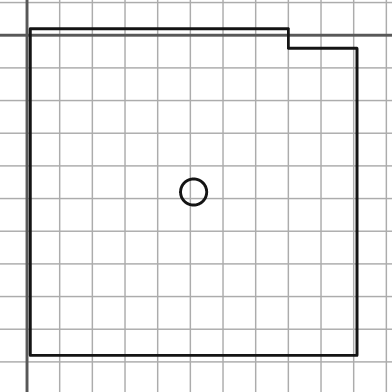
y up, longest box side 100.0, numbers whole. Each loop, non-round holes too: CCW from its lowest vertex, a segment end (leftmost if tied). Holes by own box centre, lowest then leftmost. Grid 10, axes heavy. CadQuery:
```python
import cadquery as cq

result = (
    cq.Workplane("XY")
    .moveTo(1.0, -98.0)
    .lineTo(101.0, -98.0)
    .lineTo(101.0, -4.0)
    .lineTo(80.0, -4.0)
    .lineTo(80.0, 2.0)
    .lineTo(1.0, 2.0)
    .close()
    .moveTo(51.0, -48.0)
    .circle(4.0)
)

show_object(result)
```